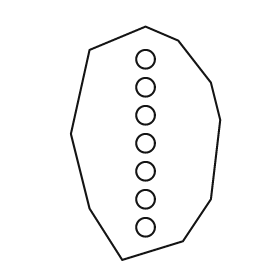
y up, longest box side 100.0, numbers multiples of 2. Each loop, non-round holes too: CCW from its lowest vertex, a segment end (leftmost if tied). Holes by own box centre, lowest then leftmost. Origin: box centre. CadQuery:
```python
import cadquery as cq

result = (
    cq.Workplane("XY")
    .moveTo(-10.0, -50.0)
    .lineTo(16.0, -42.0)
    .lineTo(28.0, -24.0)
    .lineTo(32.0, 10.0)
    .lineTo(28.0, 26.0)
    .lineTo(14.0, 44.0)
    .lineTo(0.0, 50.0)
    .lineTo(-24.0, 40.0)
    .lineTo(-32.0, 4.0)
    .lineTo(-24.0, -28.0)
    .close()
    .moveTo(0.0, -36.0)
    .circle(4.0)
    .moveTo(0.0, -24.0)
    .circle(4.0)
    .moveTo(0.0, -12.0)
    .circle(4.0)
    .moveTo(0.0, 0.0)
    .circle(4.0)
    .moveTo(0.0, 12.0)
    .circle(4.0)
    .moveTo(0.0, 24.0)
    .circle(4.0)
    .moveTo(0.0, 36.0)
    .circle(4.0)
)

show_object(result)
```